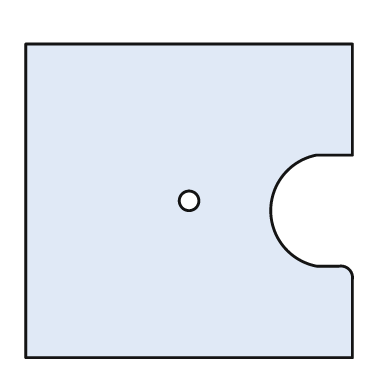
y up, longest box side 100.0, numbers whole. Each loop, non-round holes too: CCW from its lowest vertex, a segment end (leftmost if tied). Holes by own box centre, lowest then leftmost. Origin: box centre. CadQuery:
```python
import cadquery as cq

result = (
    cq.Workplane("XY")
    .moveTo(-50.0, -48.0)
    .lineTo(50.0, -48.0)
    .lineTo(50.0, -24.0)
    .threePointArc((49.0, -21.0), (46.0, -20.0))
    .lineTo(39.0, -20.0)
    .threePointArc((25.0, -3.0), (39.0, 14.0))
    .lineTo(50.0, 14.0)
    .lineTo(50.0, 48.0)
    .lineTo(-50.0, 48.0)
    .close()
    .moveTo(0.0, 0.0)
    .circle(3.0)
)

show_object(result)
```